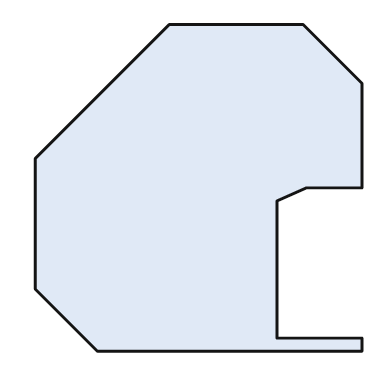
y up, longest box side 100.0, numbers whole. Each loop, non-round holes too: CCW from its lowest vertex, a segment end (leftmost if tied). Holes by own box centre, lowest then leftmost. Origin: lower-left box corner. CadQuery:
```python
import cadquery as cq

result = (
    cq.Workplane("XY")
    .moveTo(19.0, 0.0)
    .lineTo(100.0, 0.0)
    .lineTo(100.0, 4.0)
    .lineTo(74.0, 4.0)
    .lineTo(74.0, 46.0)
    .lineTo(83.0, 50.0)
    .lineTo(100.0, 50.0)
    .lineTo(100.0, 82.0)
    .lineTo(82.0, 100.0)
    .lineTo(41.0, 100.0)
    .lineTo(0.0, 59.0)
    .lineTo(0.0, 19.0)
    .close()
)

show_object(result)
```